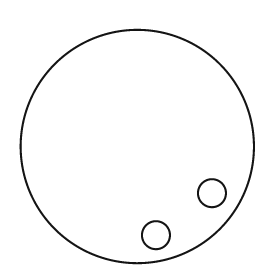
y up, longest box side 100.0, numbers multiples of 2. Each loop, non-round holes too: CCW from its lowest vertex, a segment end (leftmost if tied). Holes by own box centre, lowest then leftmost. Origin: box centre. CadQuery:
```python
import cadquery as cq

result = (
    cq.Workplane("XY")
    .moveTo(0.0, 0.0)
    .circle(50.0)
    .moveTo(8.0, -38.0)
    .circle(6.0)
    .moveTo(32.0, -20.0)
    .circle(6.0)
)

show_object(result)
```